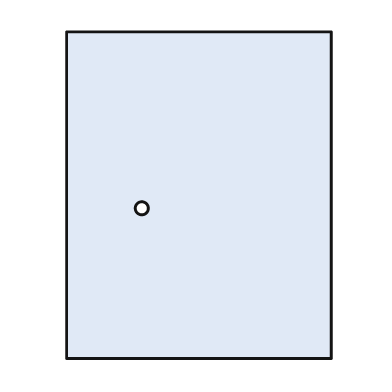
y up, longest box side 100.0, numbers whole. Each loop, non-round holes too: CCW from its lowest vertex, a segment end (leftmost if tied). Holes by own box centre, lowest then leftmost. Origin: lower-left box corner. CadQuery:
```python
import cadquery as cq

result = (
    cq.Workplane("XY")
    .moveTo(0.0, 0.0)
    .lineTo(81.0, 0.0)
    .lineTo(81.0, 100.0)
    .lineTo(0.0, 100.0)
    .close()
    .moveTo(23.0, 46.0)
    .circle(2.0)
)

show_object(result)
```